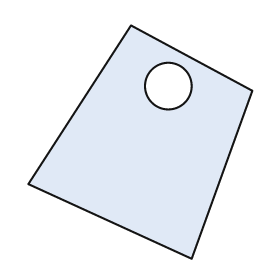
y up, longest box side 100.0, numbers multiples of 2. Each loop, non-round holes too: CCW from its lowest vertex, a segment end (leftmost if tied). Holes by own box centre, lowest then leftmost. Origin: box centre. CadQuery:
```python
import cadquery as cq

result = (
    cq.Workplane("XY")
    .moveTo(22.0, -50.0)
    .lineTo(48.0, 22.0)
    .lineTo(-4.0, 50.0)
    .lineTo(-48.0, -18.0)
    .close()
    .moveTo(12.0, 24.0)
    .circle(10.0)
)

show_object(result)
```